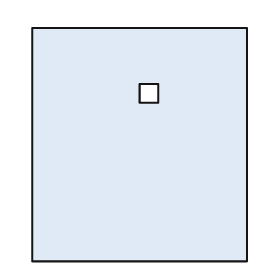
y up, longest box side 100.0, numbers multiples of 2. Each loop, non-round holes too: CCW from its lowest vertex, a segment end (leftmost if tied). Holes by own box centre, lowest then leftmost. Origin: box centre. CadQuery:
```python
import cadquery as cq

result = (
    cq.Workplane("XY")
    .moveTo(-46.0, -50.0)
    .lineTo(46.0, -50.0)
    .lineTo(46.0, 50.0)
    .lineTo(-46.0, 50.0)
    .close()
    .moveTo(0.0, 18.0)
    .lineTo(8.0, 18.0)
    .lineTo(8.0, 26.0)
    .lineTo(0.0, 26.0)
    .close()
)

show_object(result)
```